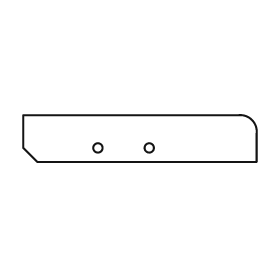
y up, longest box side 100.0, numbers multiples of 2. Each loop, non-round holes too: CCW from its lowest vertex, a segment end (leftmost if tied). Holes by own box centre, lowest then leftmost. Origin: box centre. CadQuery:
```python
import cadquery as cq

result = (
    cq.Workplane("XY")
    .moveTo(-44.0, -10.0)
    .lineTo(50.0, -10.0)
    .lineTo(50.0, 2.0)
    .threePointArc((48.0, 8.0), (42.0, 10.0))
    .lineTo(-50.0, 10.0)
    .lineTo(-50.0, -4.0)
    .close()
    .moveTo(-18.0, -4.0)
    .circle(2.0)
    .moveTo(4.0, -4.0)
    .circle(2.0)
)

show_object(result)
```